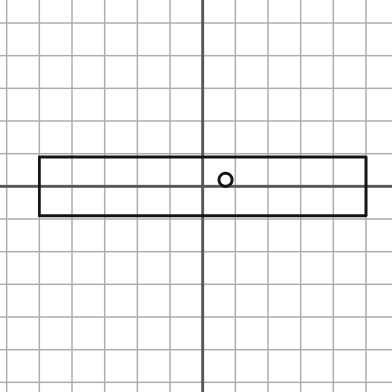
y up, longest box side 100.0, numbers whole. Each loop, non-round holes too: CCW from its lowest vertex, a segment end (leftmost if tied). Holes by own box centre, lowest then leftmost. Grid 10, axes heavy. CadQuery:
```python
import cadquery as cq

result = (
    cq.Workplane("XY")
    .moveTo(-50.0, -9.0)
    .lineTo(50.0, -9.0)
    .lineTo(50.0, 9.0)
    .lineTo(-50.0, 9.0)
    .close()
    .moveTo(7.0, 2.0)
    .circle(2.0)
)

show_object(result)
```